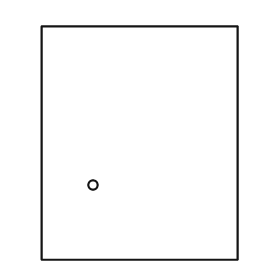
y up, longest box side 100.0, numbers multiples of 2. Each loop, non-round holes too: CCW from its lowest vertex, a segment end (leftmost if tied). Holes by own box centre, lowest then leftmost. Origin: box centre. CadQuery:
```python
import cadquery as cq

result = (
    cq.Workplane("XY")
    .moveTo(-42.0, -50.0)
    .lineTo(42.0, -50.0)
    .lineTo(42.0, 50.0)
    .lineTo(-42.0, 50.0)
    .close()
    .moveTo(-20.0, -18.0)
    .circle(2.0)
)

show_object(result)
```